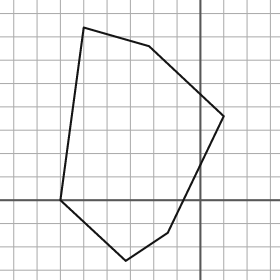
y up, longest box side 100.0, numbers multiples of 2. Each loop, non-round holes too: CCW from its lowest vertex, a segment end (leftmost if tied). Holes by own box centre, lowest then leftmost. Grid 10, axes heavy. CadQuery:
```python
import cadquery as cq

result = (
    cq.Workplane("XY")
    .moveTo(-32.0, -26.0)
    .lineTo(-14.0, -14.0)
    .lineTo(10.0, 36.0)
    .lineTo(-22.0, 66.0)
    .lineTo(-50.0, 74.0)
    .lineTo(-60.0, 0.0)
    .close()
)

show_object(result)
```